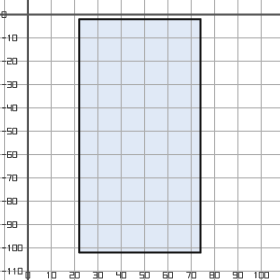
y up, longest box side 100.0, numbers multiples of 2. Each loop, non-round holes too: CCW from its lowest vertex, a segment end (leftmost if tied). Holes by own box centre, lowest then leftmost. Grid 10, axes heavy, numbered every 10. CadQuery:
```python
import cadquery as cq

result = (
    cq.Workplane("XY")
    .moveTo(22.0, -102.0)
    .lineTo(74.0, -102.0)
    .lineTo(74.0, -2.0)
    .lineTo(22.0, -2.0)
    .close()
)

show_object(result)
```